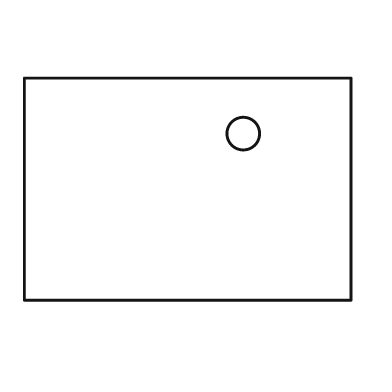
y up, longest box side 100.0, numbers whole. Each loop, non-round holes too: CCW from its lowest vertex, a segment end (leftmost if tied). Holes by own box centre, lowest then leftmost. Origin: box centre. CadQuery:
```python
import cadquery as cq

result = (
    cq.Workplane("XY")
    .moveTo(-50.0, -34.0)
    .lineTo(50.0, -34.0)
    .lineTo(50.0, 34.0)
    .lineTo(-50.0, 34.0)
    .close()
    .moveTo(17.0, 17.0)
    .circle(5.0)
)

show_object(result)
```